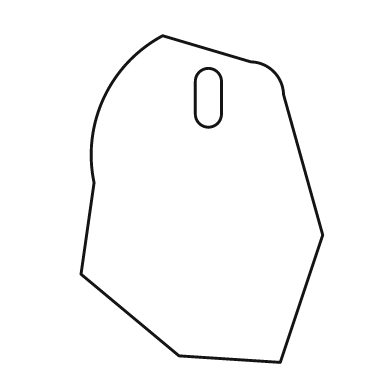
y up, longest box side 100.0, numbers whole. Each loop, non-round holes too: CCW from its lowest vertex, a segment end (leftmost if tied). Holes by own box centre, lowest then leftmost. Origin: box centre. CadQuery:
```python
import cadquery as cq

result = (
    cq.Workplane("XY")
    .moveTo(24.0, -50.0)
    .lineTo(37.0, -11.0)
    .lineTo(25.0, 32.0)
    .threePointArc((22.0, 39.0), (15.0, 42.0))
    .lineTo(-12.0, 50.0)
    .threePointArc((-30.0, 31.0), (-33.0, 5.0))
    .lineTo(-37.0, -23.0)
    .lineTo(-7.0, -48.0)
    .close()
    .moveTo(-2.0, 26.0)
    .threePointArc((2.0, 22.0), (6.0, 26.0))
    .lineTo(6.0, 36.0)
    .threePointArc((2.0, 40.0), (-2.0, 36.0))
    .close()
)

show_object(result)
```